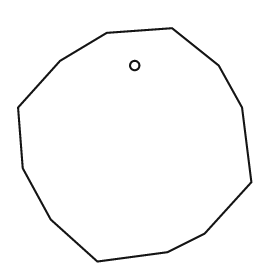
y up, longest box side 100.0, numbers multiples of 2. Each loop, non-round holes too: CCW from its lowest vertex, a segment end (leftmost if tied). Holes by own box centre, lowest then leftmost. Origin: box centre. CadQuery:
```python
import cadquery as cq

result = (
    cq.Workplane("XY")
    .moveTo(-16.0, -50.0)
    .lineTo(14.0, -46.0)
    .lineTo(30.0, -38.0)
    .lineTo(50.0, -16.0)
    .lineTo(46.0, 16.0)
    .lineTo(36.0, 34.0)
    .lineTo(16.0, 50.0)
    .lineTo(-12.0, 48.0)
    .lineTo(-32.0, 36.0)
    .lineTo(-50.0, 16.0)
    .lineTo(-48.0, -10.0)
    .lineTo(-36.0, -32.0)
    .close()
    .moveTo(0.0, 34.0)
    .circle(2.0)
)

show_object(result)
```